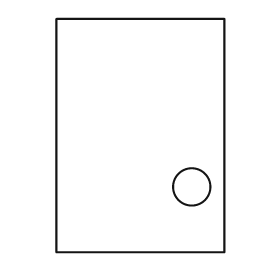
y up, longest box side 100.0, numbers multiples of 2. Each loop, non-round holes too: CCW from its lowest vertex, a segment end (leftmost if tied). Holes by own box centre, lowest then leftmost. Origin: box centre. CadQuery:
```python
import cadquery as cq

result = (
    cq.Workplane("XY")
    .moveTo(-36.0, -50.0)
    .lineTo(36.0, -50.0)
    .lineTo(36.0, 50.0)
    .lineTo(-36.0, 50.0)
    .close()
    .moveTo(22.0, -22.0)
    .circle(8.0)
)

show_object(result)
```